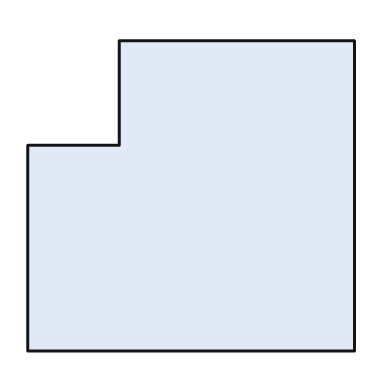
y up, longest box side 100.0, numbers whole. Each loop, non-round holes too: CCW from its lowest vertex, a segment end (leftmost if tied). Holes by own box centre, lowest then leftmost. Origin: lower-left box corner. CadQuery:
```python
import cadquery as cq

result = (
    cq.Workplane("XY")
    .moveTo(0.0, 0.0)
    .lineTo(100.0, 0.0)
    .lineTo(100.0, 95.0)
    .lineTo(28.0, 95.0)
    .lineTo(28.0, 63.0)
    .lineTo(0.0, 63.0)
    .close()
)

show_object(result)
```